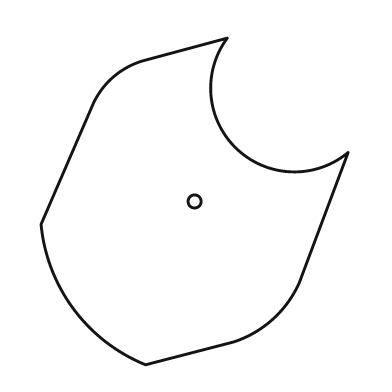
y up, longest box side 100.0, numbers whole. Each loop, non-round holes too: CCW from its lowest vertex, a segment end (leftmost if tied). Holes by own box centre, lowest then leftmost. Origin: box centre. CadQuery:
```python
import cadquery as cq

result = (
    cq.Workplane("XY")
    .moveTo(-15.0, -50.0)
    .lineTo(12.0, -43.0)
    .threePointArc((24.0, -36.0), (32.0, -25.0))
    .lineTo(47.0, 15.0)
    .threePointArc((13.0, 16.0), (10.0, 50.0))
    .lineTo(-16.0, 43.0)
    .threePointArc((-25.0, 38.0), (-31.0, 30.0))
    .lineTo(-47.0, -7.0)
    .threePointArc((-37.0, -33.0), (-15.0, -50.0))
    .close()
    .moveTo(0.0, 0.0)
    .circle(2.0)
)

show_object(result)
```